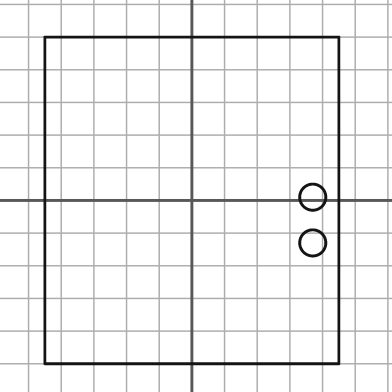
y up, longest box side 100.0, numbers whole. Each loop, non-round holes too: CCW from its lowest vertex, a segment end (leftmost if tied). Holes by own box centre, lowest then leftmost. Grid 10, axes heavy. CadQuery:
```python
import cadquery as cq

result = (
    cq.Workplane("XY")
    .moveTo(-45.0, -50.0)
    .lineTo(45.0, -50.0)
    .lineTo(45.0, 50.0)
    .lineTo(-45.0, 50.0)
    .close()
    .moveTo(37.0, -13.0)
    .circle(4.0)
    .moveTo(37.0, 1.0)
    .circle(4.0)
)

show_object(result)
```